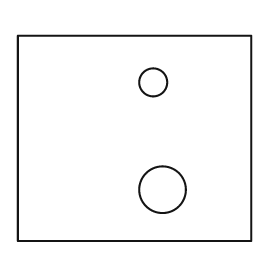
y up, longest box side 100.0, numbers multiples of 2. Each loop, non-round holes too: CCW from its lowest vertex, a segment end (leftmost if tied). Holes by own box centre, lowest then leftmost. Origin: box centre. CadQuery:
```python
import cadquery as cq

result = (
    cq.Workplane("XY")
    .moveTo(-50.0, -44.0)
    .lineTo(50.0, -44.0)
    .lineTo(50.0, 44.0)
    .lineTo(-50.0, 44.0)
    .close()
    .moveTo(12.0, -22.0)
    .circle(10.0)
    .moveTo(8.0, 24.0)
    .circle(6.0)
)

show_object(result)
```